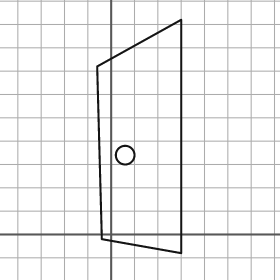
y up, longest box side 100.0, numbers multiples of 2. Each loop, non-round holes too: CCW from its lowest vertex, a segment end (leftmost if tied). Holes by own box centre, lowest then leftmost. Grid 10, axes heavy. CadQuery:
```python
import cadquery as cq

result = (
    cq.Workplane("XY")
    .moveTo(30.0, -8.0)
    .lineTo(30.0, 92.0)
    .lineTo(-6.0, 72.0)
    .lineTo(-4.0, -2.0)
    .close()
    .moveTo(6.0, 34.0)
    .circle(4.0)
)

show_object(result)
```